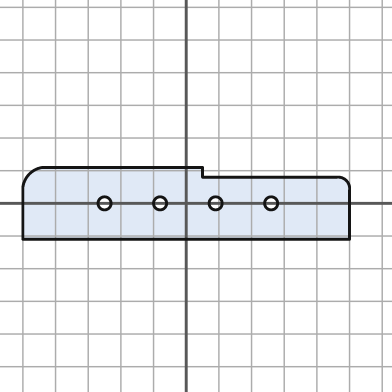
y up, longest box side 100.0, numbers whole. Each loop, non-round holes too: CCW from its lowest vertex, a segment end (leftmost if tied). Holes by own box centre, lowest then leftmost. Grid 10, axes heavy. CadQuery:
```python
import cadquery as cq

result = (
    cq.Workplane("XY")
    .moveTo(-50.0, -11.0)
    .lineTo(50.0, -11.0)
    .lineTo(50.0, 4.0)
    .threePointArc((49.0, 7.0), (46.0, 8.0))
    .lineTo(5.0, 8.0)
    .lineTo(5.0, 11.0)
    .lineTo(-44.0, 11.0)
    .threePointArc((-48.0, 9.0), (-50.0, 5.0))
    .close()
    .moveTo(-25.0, 0.0)
    .circle(2.0)
    .moveTo(-8.0, 0.0)
    .circle(2.0)
    .moveTo(9.0, 0.0)
    .circle(2.0)
    .moveTo(26.0, 0.0)
    .circle(2.0)
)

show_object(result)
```